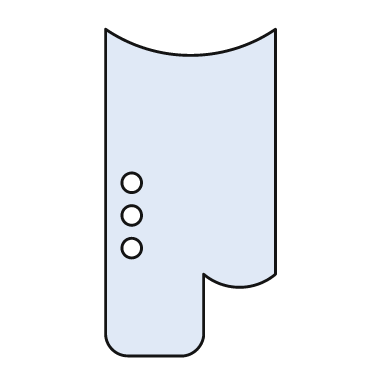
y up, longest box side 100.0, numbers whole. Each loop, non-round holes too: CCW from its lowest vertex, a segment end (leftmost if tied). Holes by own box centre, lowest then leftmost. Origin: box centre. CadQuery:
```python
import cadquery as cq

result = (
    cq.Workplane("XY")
    .moveTo(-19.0, -50.0)
    .lineTo(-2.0, -50.0)
    .threePointArc((2.0, -48.0), (4.0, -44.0))
    .lineTo(4.0, -25.0)
    .threePointArc((15.0, -29.0), (26.0, -25.0))
    .lineTo(26.0, 50.0)
    .threePointArc((0.0, 42.0), (-26.0, 50.0))
    .lineTo(-26.0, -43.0)
    .threePointArc((-24.0, -48.0), (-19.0, -50.0))
    .close()
    .moveTo(-18.0, -17.0)
    .circle(3.0)
    .moveTo(-18.0, -7.0)
    .circle(3.0)
    .moveTo(-18.0, 3.0)
    .circle(3.0)
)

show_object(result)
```